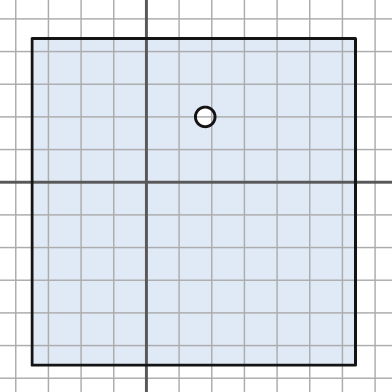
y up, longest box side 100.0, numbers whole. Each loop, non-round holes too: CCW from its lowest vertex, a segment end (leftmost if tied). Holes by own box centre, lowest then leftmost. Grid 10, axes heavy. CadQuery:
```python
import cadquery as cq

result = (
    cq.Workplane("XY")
    .moveTo(-35.0, -56.0)
    .lineTo(64.0, -56.0)
    .lineTo(64.0, 44.0)
    .lineTo(-35.0, 44.0)
    .close()
    .moveTo(18.0, 20.0)
    .circle(3.0)
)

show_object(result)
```